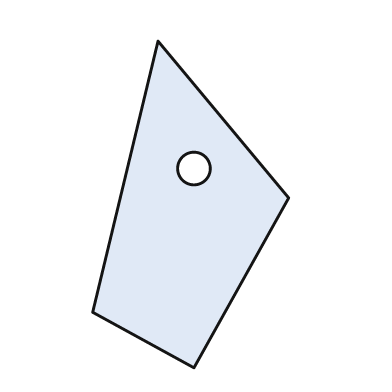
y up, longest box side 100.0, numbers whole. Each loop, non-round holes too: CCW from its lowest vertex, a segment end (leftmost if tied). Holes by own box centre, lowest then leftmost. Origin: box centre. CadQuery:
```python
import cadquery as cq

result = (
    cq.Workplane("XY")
    .moveTo(1.0, -50.0)
    .lineTo(30.0, 2.0)
    .lineTo(-10.0, 50.0)
    .lineTo(-30.0, -33.0)
    .close()
    .moveTo(1.0, 11.0)
    .circle(5.0)
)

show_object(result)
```